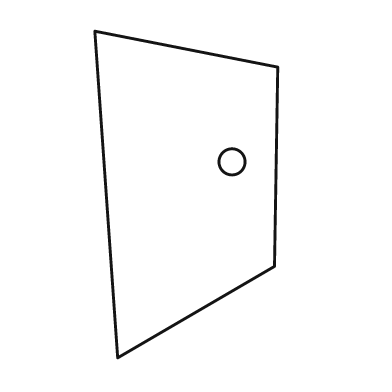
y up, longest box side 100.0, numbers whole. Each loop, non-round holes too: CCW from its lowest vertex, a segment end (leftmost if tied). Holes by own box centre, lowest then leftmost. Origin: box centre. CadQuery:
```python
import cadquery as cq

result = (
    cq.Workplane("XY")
    .moveTo(-21.0, -50.0)
    .lineTo(27.0, -22.0)
    .lineTo(28.0, 39.0)
    .lineTo(-28.0, 50.0)
    .close()
    .moveTo(14.0, 10.0)
    .circle(4.0)
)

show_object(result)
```